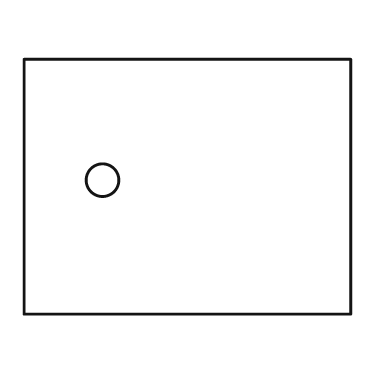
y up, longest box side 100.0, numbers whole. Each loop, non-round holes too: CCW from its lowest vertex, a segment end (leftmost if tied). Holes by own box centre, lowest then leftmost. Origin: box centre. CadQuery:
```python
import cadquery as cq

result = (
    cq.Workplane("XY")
    .moveTo(-50.0, -39.0)
    .lineTo(50.0, -39.0)
    .lineTo(50.0, 39.0)
    .lineTo(-50.0, 39.0)
    .close()
    .moveTo(-26.0, 2.0)
    .circle(5.0)
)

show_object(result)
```